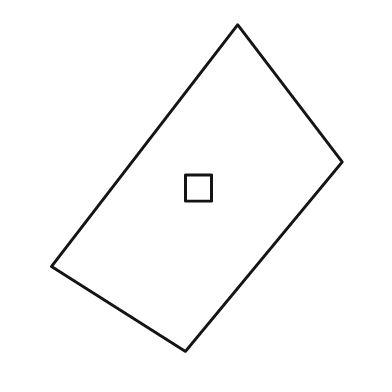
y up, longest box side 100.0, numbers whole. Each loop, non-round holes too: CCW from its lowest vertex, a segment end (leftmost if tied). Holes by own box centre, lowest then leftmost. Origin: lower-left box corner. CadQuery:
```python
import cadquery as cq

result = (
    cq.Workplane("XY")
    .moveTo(41.0, 0.0)
    .lineTo(89.0, 58.0)
    .lineTo(57.0, 100.0)
    .lineTo(0.0, 26.0)
    .close()
    .moveTo(41.0, 46.0)
    .lineTo(49.0, 46.0)
    .lineTo(49.0, 54.0)
    .lineTo(41.0, 54.0)
    .close()
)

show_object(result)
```